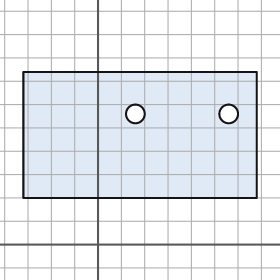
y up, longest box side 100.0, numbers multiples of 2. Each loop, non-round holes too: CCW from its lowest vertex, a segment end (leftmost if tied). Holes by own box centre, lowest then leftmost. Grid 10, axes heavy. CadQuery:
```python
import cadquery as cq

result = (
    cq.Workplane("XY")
    .moveTo(-32.0, 20.0)
    .lineTo(68.0, 20.0)
    .lineTo(68.0, 74.0)
    .lineTo(-32.0, 74.0)
    .close()
    .moveTo(16.0, 56.0)
    .circle(4.0)
    .moveTo(56.0, 56.0)
    .circle(4.0)
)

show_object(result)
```